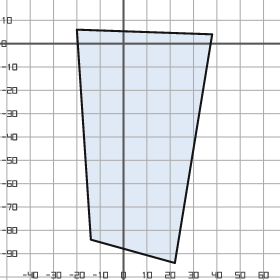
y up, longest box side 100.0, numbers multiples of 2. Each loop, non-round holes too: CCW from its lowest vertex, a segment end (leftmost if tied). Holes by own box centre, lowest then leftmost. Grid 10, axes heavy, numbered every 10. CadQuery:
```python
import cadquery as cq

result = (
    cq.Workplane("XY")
    .moveTo(22.0, -94.0)
    .lineTo(38.0, 4.0)
    .lineTo(-20.0, 6.0)
    .lineTo(-14.0, -84.0)
    .close()
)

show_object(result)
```